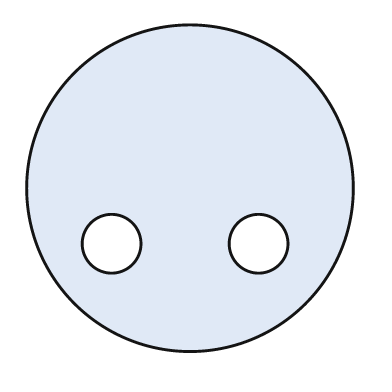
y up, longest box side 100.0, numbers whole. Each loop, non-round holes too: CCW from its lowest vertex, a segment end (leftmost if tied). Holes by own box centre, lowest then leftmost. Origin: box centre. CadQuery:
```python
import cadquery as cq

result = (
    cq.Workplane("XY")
    .moveTo(0.0, 0.0)
    .circle(50.0)
    .moveTo(-24.0, -17.0)
    .circle(9.0)
    .moveTo(21.0, -17.0)
    .circle(9.0)
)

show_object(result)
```